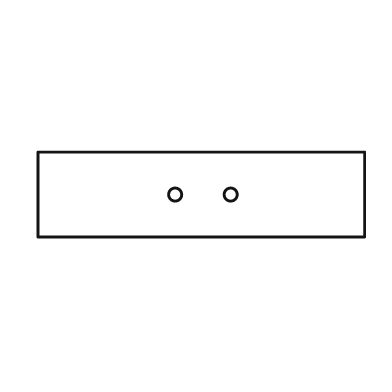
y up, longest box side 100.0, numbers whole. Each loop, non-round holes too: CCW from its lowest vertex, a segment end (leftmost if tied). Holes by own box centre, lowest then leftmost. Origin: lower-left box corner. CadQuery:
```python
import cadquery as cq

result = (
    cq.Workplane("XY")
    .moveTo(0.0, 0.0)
    .lineTo(100.0, 0.0)
    .lineTo(100.0, 26.0)
    .lineTo(0.0, 26.0)
    .close()
    .moveTo(42.0, 13.0)
    .circle(2.0)
    .moveTo(59.0, 13.0)
    .circle(2.0)
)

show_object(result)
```